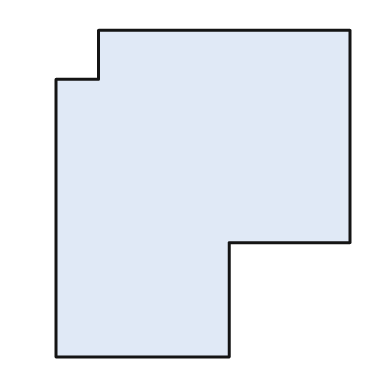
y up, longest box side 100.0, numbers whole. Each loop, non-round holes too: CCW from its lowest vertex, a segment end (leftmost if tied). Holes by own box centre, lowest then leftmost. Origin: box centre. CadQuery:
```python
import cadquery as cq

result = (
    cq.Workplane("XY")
    .moveTo(-45.0, -50.0)
    .lineTo(8.0, -50.0)
    .lineTo(8.0, -15.0)
    .lineTo(45.0, -15.0)
    .lineTo(45.0, 50.0)
    .lineTo(-32.0, 50.0)
    .lineTo(-32.0, 35.0)
    .lineTo(-45.0, 35.0)
    .close()
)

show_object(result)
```